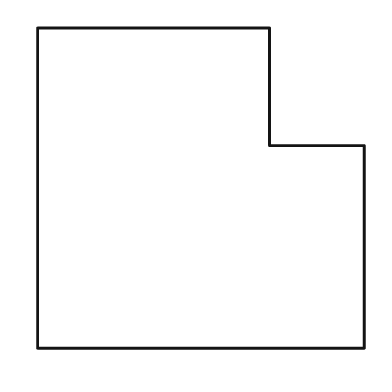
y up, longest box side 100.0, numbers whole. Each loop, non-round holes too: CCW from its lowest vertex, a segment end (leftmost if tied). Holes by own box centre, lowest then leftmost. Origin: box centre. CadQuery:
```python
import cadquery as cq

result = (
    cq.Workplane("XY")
    .moveTo(-50.0, -49.0)
    .lineTo(50.0, -49.0)
    .lineTo(50.0, 13.0)
    .lineTo(21.0, 13.0)
    .lineTo(21.0, 49.0)
    .lineTo(-50.0, 49.0)
    .close()
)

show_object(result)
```